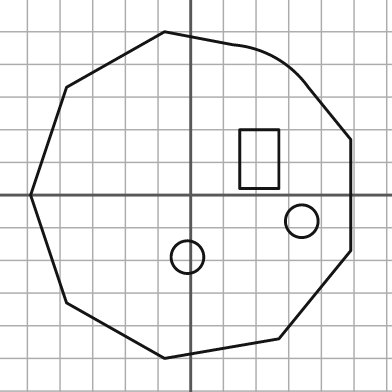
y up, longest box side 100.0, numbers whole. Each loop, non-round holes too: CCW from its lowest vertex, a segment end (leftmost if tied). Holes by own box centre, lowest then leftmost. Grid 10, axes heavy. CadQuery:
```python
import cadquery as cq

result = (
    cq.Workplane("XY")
    .moveTo(-8.0, -50.0)
    .lineTo(27.0, -44.0)
    .lineTo(49.0, -17.0)
    .lineTo(49.0, 17.0)
    .lineTo(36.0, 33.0)
    .threePointArc((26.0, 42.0), (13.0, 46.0))
    .lineTo(-8.0, 50.0)
    .lineTo(-38.0, 33.0)
    .lineTo(-49.0, 0.0)
    .lineTo(-38.0, -33.0)
    .close()
    .moveTo(-1.0, -19.0)
    .circle(5.0)
    .moveTo(34.0, -8.0)
    .circle(5.0)
    .moveTo(15.0, 2.0)
    .lineTo(27.0, 2.0)
    .lineTo(27.0, 20.0)
    .lineTo(15.0, 20.0)
    .close()
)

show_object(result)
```